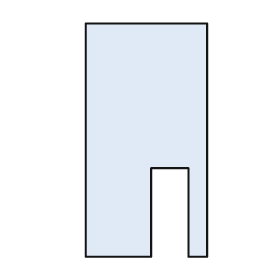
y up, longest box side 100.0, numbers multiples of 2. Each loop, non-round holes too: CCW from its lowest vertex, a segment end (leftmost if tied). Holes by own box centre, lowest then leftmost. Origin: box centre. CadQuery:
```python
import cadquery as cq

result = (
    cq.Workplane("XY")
    .moveTo(-26.0, -50.0)
    .lineTo(2.0, -50.0)
    .lineTo(2.0, -12.0)
    .lineTo(18.0, -12.0)
    .lineTo(18.0, -50.0)
    .lineTo(26.0, -50.0)
    .lineTo(26.0, 50.0)
    .lineTo(-26.0, 50.0)
    .close()
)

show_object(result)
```